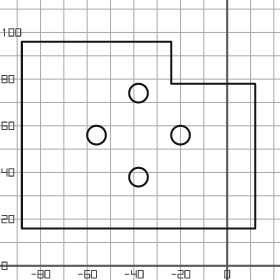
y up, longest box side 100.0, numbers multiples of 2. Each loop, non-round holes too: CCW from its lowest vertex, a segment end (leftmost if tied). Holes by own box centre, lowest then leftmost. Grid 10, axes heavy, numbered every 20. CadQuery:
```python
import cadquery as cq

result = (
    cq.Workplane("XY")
    .moveTo(-88.0, 16.0)
    .lineTo(12.0, 16.0)
    .lineTo(12.0, 78.0)
    .lineTo(-24.0, 78.0)
    .lineTo(-24.0, 96.0)
    .lineTo(-88.0, 96.0)
    .close()
    .moveTo(-38.0, 38.0)
    .circle(4.0)
    .moveTo(-56.0, 56.0)
    .circle(4.0)
    .moveTo(-20.0, 56.0)
    .circle(4.0)
    .moveTo(-38.0, 74.0)
    .circle(4.0)
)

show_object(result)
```